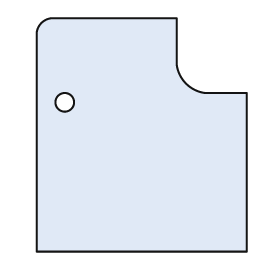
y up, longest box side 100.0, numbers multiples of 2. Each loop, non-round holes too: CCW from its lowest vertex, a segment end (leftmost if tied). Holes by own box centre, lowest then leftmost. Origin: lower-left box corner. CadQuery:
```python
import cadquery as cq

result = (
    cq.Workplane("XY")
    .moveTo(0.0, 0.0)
    .lineTo(90.0, 0.0)
    .lineTo(90.0, 68.0)
    .lineTo(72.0, 68.0)
    .threePointArc((64.0, 72.0), (60.0, 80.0))
    .lineTo(60.0, 100.0)
    .lineTo(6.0, 100.0)
    .threePointArc((2.0, 98.0), (0.0, 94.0))
    .close()
    .moveTo(12.0, 64.0)
    .circle(4.0)
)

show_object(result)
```